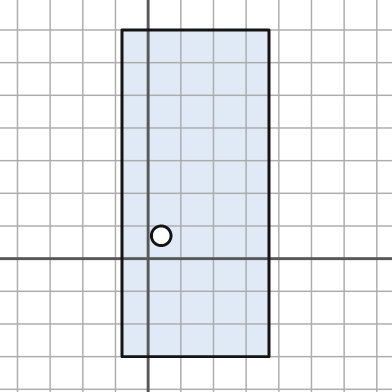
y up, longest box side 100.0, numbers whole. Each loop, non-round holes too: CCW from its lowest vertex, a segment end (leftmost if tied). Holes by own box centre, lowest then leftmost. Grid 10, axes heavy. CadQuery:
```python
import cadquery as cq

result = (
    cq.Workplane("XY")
    .moveTo(-8.0, -30.0)
    .lineTo(37.0, -30.0)
    .lineTo(37.0, 70.0)
    .lineTo(-8.0, 70.0)
    .close()
    .moveTo(4.0, 7.0)
    .circle(3.0)
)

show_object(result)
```